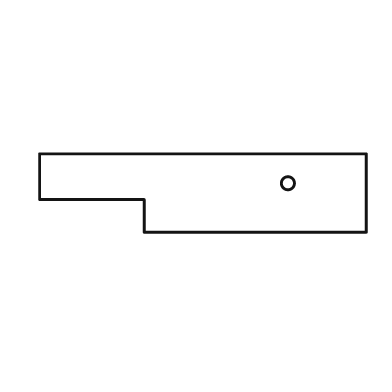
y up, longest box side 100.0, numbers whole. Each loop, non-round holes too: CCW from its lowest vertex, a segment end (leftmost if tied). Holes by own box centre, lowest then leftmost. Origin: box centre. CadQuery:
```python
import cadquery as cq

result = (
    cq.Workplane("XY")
    .moveTo(-18.0, -12.0)
    .lineTo(50.0, -12.0)
    .lineTo(50.0, 12.0)
    .lineTo(-50.0, 12.0)
    .lineTo(-50.0, -2.0)
    .lineTo(-18.0, -2.0)
    .close()
    .moveTo(26.0, 3.0)
    .circle(2.0)
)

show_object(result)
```